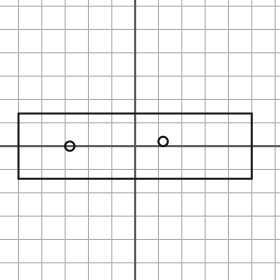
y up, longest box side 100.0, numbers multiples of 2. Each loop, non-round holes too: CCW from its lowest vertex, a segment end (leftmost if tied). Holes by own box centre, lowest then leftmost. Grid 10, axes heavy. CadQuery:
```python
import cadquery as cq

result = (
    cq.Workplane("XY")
    .moveTo(-50.0, -14.0)
    .lineTo(50.0, -14.0)
    .lineTo(50.0, 14.0)
    .lineTo(-50.0, 14.0)
    .close()
    .moveTo(-28.0, 0.0)
    .circle(2.0)
    .moveTo(12.0, 2.0)
    .circle(2.0)
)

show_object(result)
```